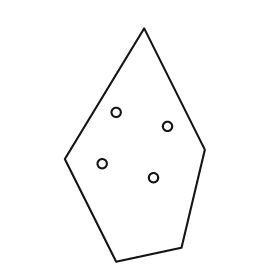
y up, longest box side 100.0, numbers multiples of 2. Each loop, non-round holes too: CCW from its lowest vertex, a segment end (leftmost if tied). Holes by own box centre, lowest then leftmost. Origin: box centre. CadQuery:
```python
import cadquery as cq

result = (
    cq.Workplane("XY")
    .moveTo(-8.0, -50.0)
    .lineTo(20.0, -44.0)
    .lineTo(30.0, -2.0)
    .lineTo(4.0, 50.0)
    .lineTo(-30.0, -6.0)
    .close()
    .moveTo(8.0, -14.0)
    .circle(2.0)
    .moveTo(-14.0, -8.0)
    .circle(2.0)
    .moveTo(14.0, 8.0)
    .circle(2.0)
    .moveTo(-8.0, 14.0)
    .circle(2.0)
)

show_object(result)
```